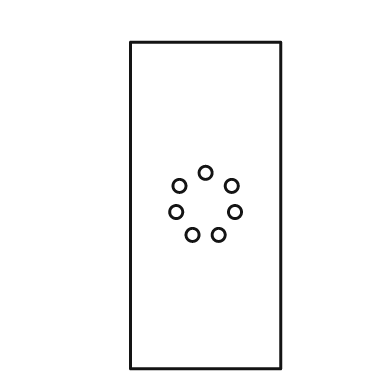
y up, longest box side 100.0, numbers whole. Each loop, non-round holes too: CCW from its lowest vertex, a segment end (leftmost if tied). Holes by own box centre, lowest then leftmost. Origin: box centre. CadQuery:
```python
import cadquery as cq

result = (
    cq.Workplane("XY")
    .moveTo(-23.0, -50.0)
    .lineTo(23.0, -50.0)
    .lineTo(23.0, 50.0)
    .lineTo(-23.0, 50.0)
    .close()
    .moveTo(-4.0, -9.0)
    .circle(2.0)
    .moveTo(4.0, -9.0)
    .circle(2.0)
    .moveTo(-9.0, -2.0)
    .circle(2.0)
    .moveTo(9.0, -2.0)
    .circle(2.0)
    .moveTo(-8.0, 6.0)
    .circle(2.0)
    .moveTo(8.0, 6.0)
    .circle(2.0)
    .moveTo(0.0, 10.0)
    .circle(2.0)
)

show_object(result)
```